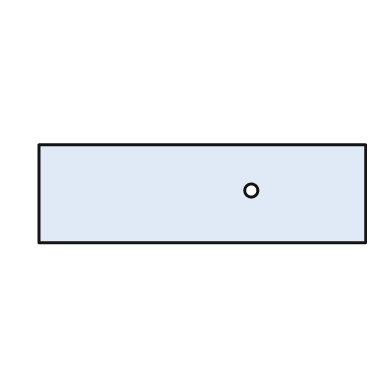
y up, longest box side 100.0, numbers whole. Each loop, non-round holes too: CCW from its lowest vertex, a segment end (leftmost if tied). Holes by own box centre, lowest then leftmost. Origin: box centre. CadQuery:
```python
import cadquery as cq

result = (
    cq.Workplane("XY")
    .moveTo(-50.0, -15.0)
    .lineTo(50.0, -15.0)
    .lineTo(50.0, 15.0)
    .lineTo(-50.0, 15.0)
    .close()
    .moveTo(15.0, 1.0)
    .circle(2.0)
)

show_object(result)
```